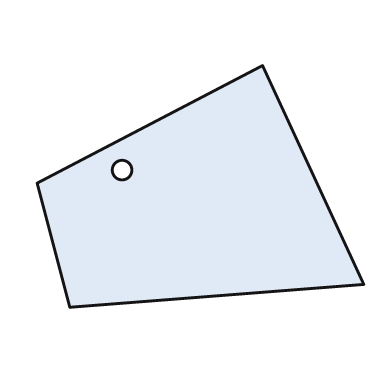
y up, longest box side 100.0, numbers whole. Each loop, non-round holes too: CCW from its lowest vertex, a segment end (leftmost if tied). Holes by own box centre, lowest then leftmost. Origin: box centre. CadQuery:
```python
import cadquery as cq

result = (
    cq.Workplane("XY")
    .moveTo(-40.0, -37.0)
    .lineTo(50.0, -30.0)
    .lineTo(19.0, 37.0)
    .lineTo(-50.0, 1.0)
    .close()
    .moveTo(-24.0, 5.0)
    .circle(3.0)
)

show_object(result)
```